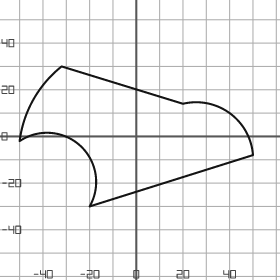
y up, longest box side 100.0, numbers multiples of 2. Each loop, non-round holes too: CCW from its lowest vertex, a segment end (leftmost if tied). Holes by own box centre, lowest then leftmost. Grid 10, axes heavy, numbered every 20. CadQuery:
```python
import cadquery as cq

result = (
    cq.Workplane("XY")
    .moveTo(-20.0, -30.0)
    .lineTo(50.0, -8.0)
    .threePointArc((40.0, 10.0), (20.0, 14.0))
    .lineTo(-32.0, 30.0)
    .threePointArc((-44.0, 16.0), (-50.0, -2.0))
    .threePointArc((-24.0, -4.0), (-20.0, -30.0))
    .close()
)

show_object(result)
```